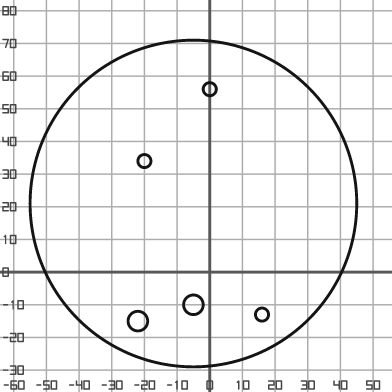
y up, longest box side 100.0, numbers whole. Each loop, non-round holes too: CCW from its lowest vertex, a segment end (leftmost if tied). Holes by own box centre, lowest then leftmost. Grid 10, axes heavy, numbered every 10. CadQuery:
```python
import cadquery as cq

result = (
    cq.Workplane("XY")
    .moveTo(-5.0, 21.0)
    .circle(50.0)
    .moveTo(-22.0, -15.0)
    .circle(3.0)
    .moveTo(16.0, -13.0)
    .circle(2.0)
    .moveTo(-5.0, -10.0)
    .circle(3.0)
    .moveTo(-20.0, 34.0)
    .circle(2.0)
    .moveTo(0.0, 56.0)
    .circle(2.0)
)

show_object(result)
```